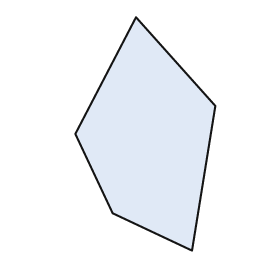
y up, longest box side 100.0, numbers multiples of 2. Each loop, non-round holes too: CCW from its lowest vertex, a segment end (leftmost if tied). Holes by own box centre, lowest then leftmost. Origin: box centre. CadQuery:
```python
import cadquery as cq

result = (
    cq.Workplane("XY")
    .moveTo(20.0, -50.0)
    .lineTo(30.0, 12.0)
    .lineTo(-4.0, 50.0)
    .lineTo(-30.0, 0.0)
    .lineTo(-14.0, -34.0)
    .close()
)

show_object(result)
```